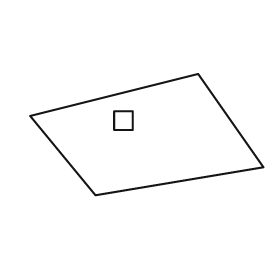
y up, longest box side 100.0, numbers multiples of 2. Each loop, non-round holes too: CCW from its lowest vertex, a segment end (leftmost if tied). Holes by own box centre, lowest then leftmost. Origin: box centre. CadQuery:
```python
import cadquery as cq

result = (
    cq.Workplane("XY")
    .moveTo(-22.0, -26.0)
    .lineTo(50.0, -14.0)
    .lineTo(22.0, 26.0)
    .lineTo(-50.0, 8.0)
    .close()
    .moveTo(-14.0, 2.0)
    .lineTo(-6.0, 2.0)
    .lineTo(-6.0, 10.0)
    .lineTo(-14.0, 10.0)
    .close()
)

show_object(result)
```